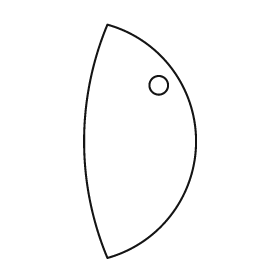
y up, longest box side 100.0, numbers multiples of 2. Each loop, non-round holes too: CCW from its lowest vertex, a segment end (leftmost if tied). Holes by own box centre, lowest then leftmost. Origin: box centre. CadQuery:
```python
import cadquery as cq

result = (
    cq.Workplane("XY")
    .moveTo(-14.0, -50.0)
    .threePointArc((24.0, 0.0), (-14.0, 50.0))
    .threePointArc((-24.0, 0.0), (-14.0, -50.0))
    .close()
    .moveTo(8.0, 24.0)
    .circle(4.0)
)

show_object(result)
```